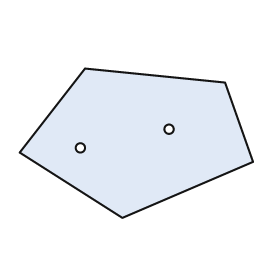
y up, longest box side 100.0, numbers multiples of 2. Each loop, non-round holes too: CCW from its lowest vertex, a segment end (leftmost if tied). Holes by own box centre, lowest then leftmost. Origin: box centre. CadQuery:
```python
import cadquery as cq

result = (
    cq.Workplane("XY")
    .moveTo(-6.0, -32.0)
    .lineTo(50.0, -8.0)
    .lineTo(38.0, 26.0)
    .lineTo(-22.0, 32.0)
    .lineTo(-50.0, -4.0)
    .close()
    .moveTo(-24.0, -2.0)
    .circle(2.0)
    .moveTo(14.0, 6.0)
    .circle(2.0)
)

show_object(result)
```